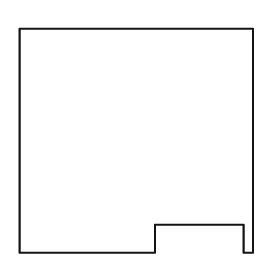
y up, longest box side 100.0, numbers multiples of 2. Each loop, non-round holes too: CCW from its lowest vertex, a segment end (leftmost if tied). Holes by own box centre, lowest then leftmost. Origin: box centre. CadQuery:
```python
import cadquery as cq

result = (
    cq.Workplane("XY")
    .moveTo(-50.0, -48.0)
    .lineTo(8.0, -48.0)
    .lineTo(8.0, -36.0)
    .lineTo(46.0, -36.0)
    .lineTo(46.0, -48.0)
    .lineTo(50.0, -48.0)
    .lineTo(50.0, 48.0)
    .lineTo(-50.0, 48.0)
    .close()
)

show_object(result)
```